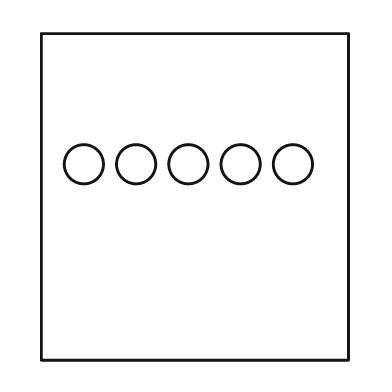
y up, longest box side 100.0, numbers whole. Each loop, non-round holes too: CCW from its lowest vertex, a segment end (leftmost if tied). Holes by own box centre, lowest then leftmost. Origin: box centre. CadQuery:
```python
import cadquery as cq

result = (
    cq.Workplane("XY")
    .moveTo(-47.0, -50.0)
    .lineTo(47.0, -50.0)
    .lineTo(47.0, 50.0)
    .lineTo(-47.0, 50.0)
    .close()
    .moveTo(-34.0, 10.0)
    .circle(6.0)
    .moveTo(-18.0, 10.0)
    .circle(6.0)
    .moveTo(-2.0, 10.0)
    .circle(6.0)
    .moveTo(14.0, 10.0)
    .circle(6.0)
    .moveTo(30.0, 10.0)
    .circle(6.0)
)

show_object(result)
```